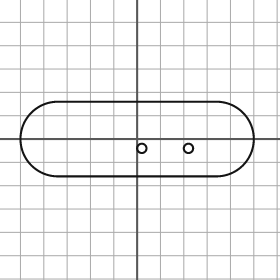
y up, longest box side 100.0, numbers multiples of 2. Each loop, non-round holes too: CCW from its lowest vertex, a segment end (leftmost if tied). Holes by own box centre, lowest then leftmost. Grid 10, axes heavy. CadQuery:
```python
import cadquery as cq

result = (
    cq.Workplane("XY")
    .moveTo(-34.0, -16.0)
    .lineTo(34.0, -16.0)
    .threePointArc((50.0, 0.0), (34.0, 16.0))
    .lineTo(-34.0, 16.0)
    .threePointArc((-50.0, 0.0), (-34.0, -16.0))
    .close()
    .moveTo(2.0, -4.0)
    .circle(2.0)
    .moveTo(22.0, -4.0)
    .circle(2.0)
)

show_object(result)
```